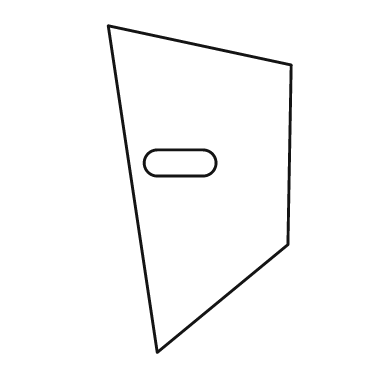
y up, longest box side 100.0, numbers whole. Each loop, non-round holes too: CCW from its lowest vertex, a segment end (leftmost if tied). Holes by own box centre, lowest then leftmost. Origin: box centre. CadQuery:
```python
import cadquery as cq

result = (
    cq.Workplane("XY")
    .moveTo(-13.0, -50.0)
    .lineTo(27.0, -17.0)
    .lineTo(28.0, 38.0)
    .lineTo(-28.0, 50.0)
    .close()
    .moveTo(-13.0, 4.0)
    .lineTo(1.0, 4.0)
    .threePointArc((5.0, 8.0), (1.0, 12.0))
    .lineTo(-13.0, 12.0)
    .threePointArc((-17.0, 8.0), (-13.0, 4.0))
    .close()
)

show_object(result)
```